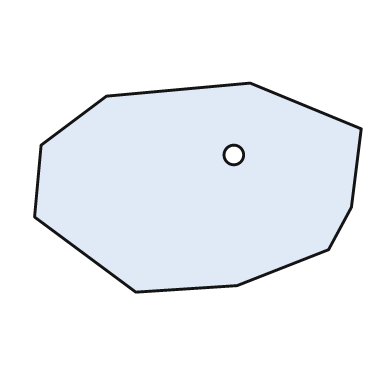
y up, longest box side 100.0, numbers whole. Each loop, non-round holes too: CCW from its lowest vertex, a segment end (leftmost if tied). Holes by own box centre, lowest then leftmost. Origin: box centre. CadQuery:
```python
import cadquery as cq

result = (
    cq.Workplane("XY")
    .moveTo(-19.0, -32.0)
    .lineTo(12.0, -30.0)
    .lineTo(40.0, -19.0)
    .lineTo(47.0, -6.0)
    .lineTo(50.0, 18.0)
    .lineTo(16.0, 32.0)
    .lineTo(-28.0, 28.0)
    .lineTo(-48.0, 13.0)
    .lineTo(-50.0, -9.0)
    .close()
    .moveTo(11.0, 10.0)
    .circle(3.0)
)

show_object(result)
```